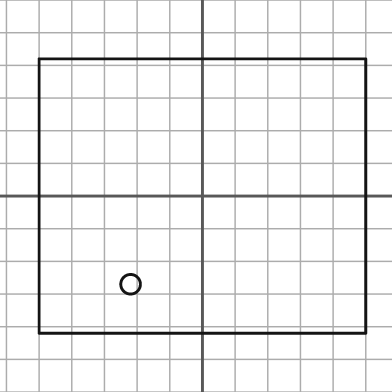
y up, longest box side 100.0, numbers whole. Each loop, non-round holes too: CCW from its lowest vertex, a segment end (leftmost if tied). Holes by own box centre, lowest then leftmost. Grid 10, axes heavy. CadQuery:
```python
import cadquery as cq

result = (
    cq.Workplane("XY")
    .moveTo(-50.0, -42.0)
    .lineTo(50.0, -42.0)
    .lineTo(50.0, 42.0)
    .lineTo(-50.0, 42.0)
    .close()
    .moveTo(-22.0, -27.0)
    .circle(3.0)
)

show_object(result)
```